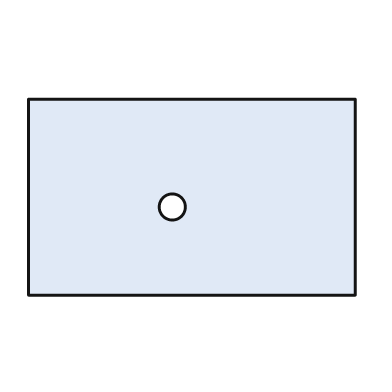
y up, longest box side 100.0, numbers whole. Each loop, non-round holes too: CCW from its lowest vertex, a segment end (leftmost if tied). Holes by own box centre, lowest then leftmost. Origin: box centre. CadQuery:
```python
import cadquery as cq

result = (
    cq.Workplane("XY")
    .moveTo(-50.0, -30.0)
    .lineTo(50.0, -30.0)
    .lineTo(50.0, 30.0)
    .lineTo(-50.0, 30.0)
    .close()
    .moveTo(-6.0, -3.0)
    .circle(4.0)
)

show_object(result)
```